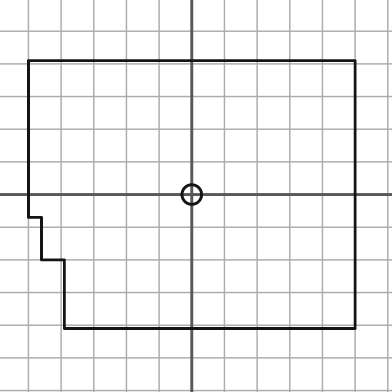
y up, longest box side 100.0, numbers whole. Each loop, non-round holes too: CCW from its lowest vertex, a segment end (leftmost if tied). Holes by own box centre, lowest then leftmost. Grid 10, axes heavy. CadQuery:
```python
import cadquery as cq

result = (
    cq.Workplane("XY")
    .moveTo(-39.0, -41.0)
    .lineTo(50.0, -41.0)
    .lineTo(50.0, 41.0)
    .lineTo(-50.0, 41.0)
    .lineTo(-50.0, -7.0)
    .lineTo(-46.0, -7.0)
    .lineTo(-46.0, -20.0)
    .lineTo(-39.0, -20.0)
    .close()
    .moveTo(0.0, 0.0)
    .circle(3.0)
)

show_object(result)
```